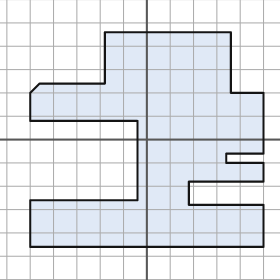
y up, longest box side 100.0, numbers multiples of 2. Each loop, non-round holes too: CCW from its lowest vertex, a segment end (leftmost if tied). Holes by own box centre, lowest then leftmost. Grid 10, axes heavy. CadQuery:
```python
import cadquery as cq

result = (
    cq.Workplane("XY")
    .moveTo(-50.0, -46.0)
    .lineTo(50.0, -46.0)
    .lineTo(50.0, -28.0)
    .lineTo(18.0, -28.0)
    .lineTo(18.0, -18.0)
    .lineTo(50.0, -18.0)
    .lineTo(50.0, -10.0)
    .lineTo(34.0, -10.0)
    .lineTo(34.0, -6.0)
    .lineTo(50.0, -6.0)
    .lineTo(50.0, 20.0)
    .lineTo(36.0, 20.0)
    .lineTo(36.0, 46.0)
    .lineTo(-18.0, 46.0)
    .lineTo(-18.0, 24.0)
    .lineTo(-46.0, 24.0)
    .lineTo(-50.0, 20.0)
    .lineTo(-50.0, 8.0)
    .lineTo(-4.0, 8.0)
    .lineTo(-4.0, -26.0)
    .lineTo(-50.0, -26.0)
    .close()
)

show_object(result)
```